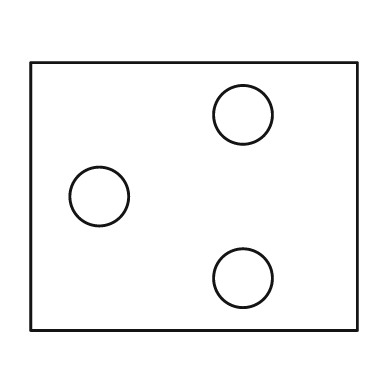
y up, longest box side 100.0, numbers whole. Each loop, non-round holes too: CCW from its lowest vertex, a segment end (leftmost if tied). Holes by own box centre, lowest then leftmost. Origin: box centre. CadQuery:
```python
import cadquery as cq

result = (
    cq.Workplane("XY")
    .moveTo(-50.0, -41.0)
    .lineTo(50.0, -41.0)
    .lineTo(50.0, 41.0)
    .lineTo(-50.0, 41.0)
    .close()
    .moveTo(15.0, -25.0)
    .circle(9.0)
    .moveTo(-29.0, 0.0)
    .circle(9.0)
    .moveTo(15.0, 25.0)
    .circle(9.0)
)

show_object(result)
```